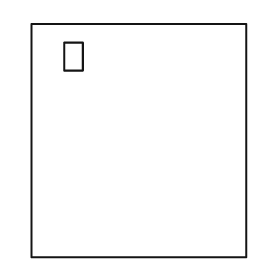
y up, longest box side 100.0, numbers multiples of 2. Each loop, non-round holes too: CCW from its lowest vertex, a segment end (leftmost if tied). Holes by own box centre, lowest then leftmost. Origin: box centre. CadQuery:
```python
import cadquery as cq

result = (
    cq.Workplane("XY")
    .moveTo(-46.0, -50.0)
    .lineTo(46.0, -50.0)
    .lineTo(46.0, 50.0)
    .lineTo(-46.0, 50.0)
    .close()
    .moveTo(-32.0, 30.0)
    .lineTo(-24.0, 30.0)
    .lineTo(-24.0, 42.0)
    .lineTo(-32.0, 42.0)
    .close()
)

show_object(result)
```